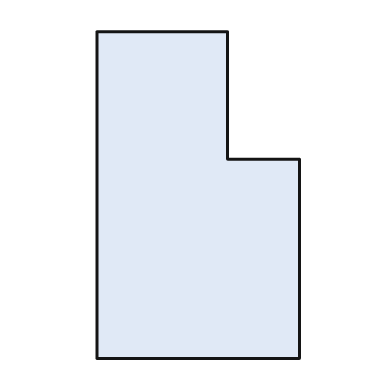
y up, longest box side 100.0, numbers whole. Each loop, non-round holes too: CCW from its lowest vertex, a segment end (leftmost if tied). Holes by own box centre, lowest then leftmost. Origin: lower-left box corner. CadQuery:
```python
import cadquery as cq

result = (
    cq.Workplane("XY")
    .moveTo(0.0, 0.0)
    .lineTo(62.0, 0.0)
    .lineTo(62.0, 61.0)
    .lineTo(40.0, 61.0)
    .lineTo(40.0, 100.0)
    .lineTo(0.0, 100.0)
    .close()
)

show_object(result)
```